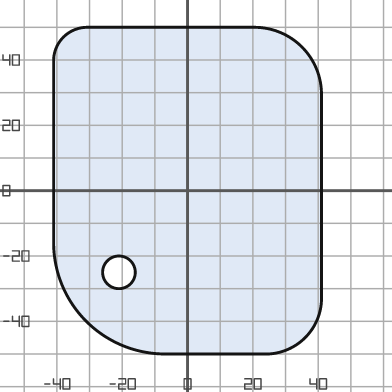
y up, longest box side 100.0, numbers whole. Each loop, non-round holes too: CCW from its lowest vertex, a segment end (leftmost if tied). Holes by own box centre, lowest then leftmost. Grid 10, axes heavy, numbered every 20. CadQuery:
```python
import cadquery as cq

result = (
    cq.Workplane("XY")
    .moveTo(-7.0, -50.0)
    .lineTo(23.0, -50.0)
    .threePointArc((36.0, -45.0), (41.0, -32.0))
    .lineTo(41.0, 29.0)
    .threePointArc((35.0, 44.0), (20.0, 50.0))
    .lineTo(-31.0, 50.0)
    .threePointArc((-38.0, 47.0), (-41.0, 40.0))
    .lineTo(-41.0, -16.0)
    .threePointArc((-31.0, -40.0), (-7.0, -50.0))
    .close()
    .moveTo(-21.0, -25.0)
    .circle(5.0)
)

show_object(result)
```